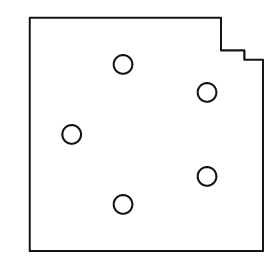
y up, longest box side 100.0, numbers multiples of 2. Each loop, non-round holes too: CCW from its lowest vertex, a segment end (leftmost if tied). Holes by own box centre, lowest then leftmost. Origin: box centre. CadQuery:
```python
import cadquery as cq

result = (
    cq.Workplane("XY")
    .moveTo(-50.0, -50.0)
    .lineTo(50.0, -50.0)
    .lineTo(50.0, 32.0)
    .lineTo(42.0, 32.0)
    .lineTo(42.0, 36.0)
    .lineTo(32.0, 36.0)
    .lineTo(32.0, 50.0)
    .lineTo(-50.0, 50.0)
    .close()
    .moveTo(-10.0, -30.0)
    .circle(4.0)
    .moveTo(26.0, -18.0)
    .circle(4.0)
    .moveTo(-32.0, 0.0)
    .circle(4.0)
    .moveTo(26.0, 18.0)
    .circle(4.0)
    .moveTo(-10.0, 30.0)
    .circle(4.0)
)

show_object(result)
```